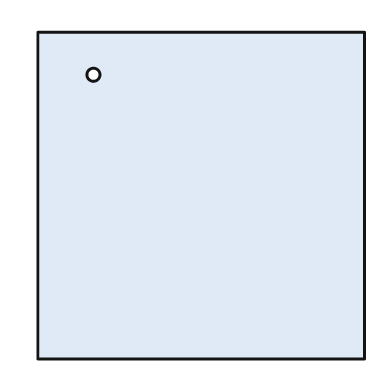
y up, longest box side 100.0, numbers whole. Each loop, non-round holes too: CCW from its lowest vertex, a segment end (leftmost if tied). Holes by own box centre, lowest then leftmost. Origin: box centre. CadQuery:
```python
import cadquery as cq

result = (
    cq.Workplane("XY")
    .moveTo(-50.0, -50.0)
    .lineTo(50.0, -50.0)
    .lineTo(50.0, 50.0)
    .lineTo(-50.0, 50.0)
    .close()
    .moveTo(-33.0, 37.0)
    .circle(2.0)
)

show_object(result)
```